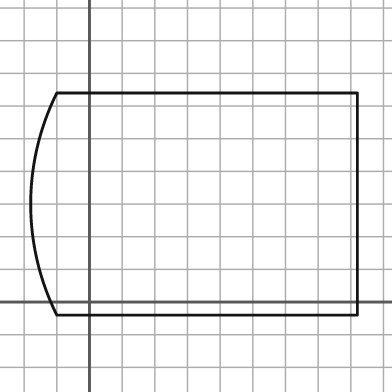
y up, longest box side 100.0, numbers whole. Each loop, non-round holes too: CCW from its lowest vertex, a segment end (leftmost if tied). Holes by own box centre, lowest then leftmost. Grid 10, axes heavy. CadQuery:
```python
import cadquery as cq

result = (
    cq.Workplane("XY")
    .moveTo(-10.0, -4.0)
    .lineTo(82.0, -4.0)
    .lineTo(82.0, 64.0)
    .lineTo(-10.0, 64.0)
    .threePointArc((-18.0, 30.0), (-10.0, -4.0))
    .close()
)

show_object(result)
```